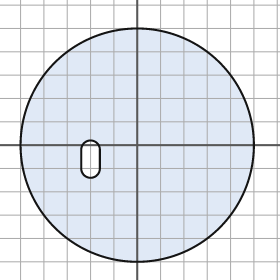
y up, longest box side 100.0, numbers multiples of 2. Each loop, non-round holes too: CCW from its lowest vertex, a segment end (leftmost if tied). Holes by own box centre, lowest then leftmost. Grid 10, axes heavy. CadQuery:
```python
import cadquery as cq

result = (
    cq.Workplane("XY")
    .moveTo(0.0, 0.0)
    .circle(50.0)
    .moveTo(-24.0, -10.0)
    .threePointArc((-20.0, -14.0), (-16.0, -10.0))
    .lineTo(-16.0, -2.0)
    .threePointArc((-20.0, 2.0), (-24.0, -2.0))
    .close()
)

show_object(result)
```